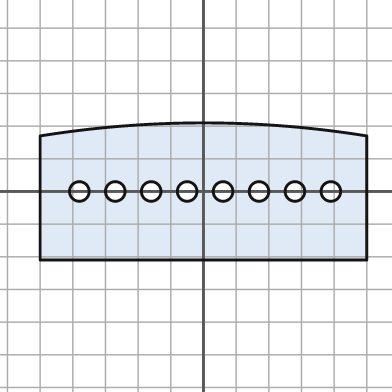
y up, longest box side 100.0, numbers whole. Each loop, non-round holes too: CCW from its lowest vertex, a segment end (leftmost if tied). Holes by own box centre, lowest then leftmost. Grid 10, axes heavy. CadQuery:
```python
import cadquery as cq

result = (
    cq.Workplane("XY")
    .moveTo(-50.0, -21.0)
    .lineTo(50.0, -21.0)
    .lineTo(50.0, 17.0)
    .threePointArc((0.0, 21.0), (-50.0, 17.0))
    .close()
    .moveTo(-38.0, 0.0)
    .circle(3.0)
    .moveTo(-27.0, 0.0)
    .circle(3.0)
    .moveTo(-16.0, 0.0)
    .circle(3.0)
    .moveTo(-5.0, 0.0)
    .circle(3.0)
    .moveTo(6.0, 0.0)
    .circle(3.0)
    .moveTo(17.0, 0.0)
    .circle(3.0)
    .moveTo(28.0, 0.0)
    .circle(3.0)
    .moveTo(39.0, 0.0)
    .circle(3.0)
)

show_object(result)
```